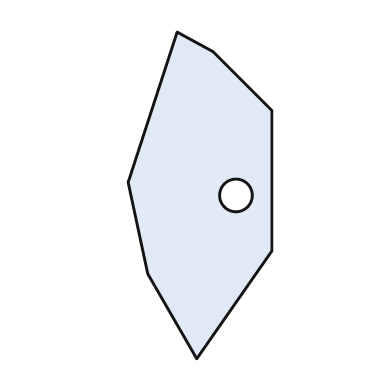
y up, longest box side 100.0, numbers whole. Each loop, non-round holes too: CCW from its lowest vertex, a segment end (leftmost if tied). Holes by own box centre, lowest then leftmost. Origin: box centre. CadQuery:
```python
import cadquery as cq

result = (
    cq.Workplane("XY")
    .moveTo(-1.0, -50.0)
    .lineTo(22.0, -17.0)
    .lineTo(22.0, 26.0)
    .lineTo(4.0, 44.0)
    .lineTo(-7.0, 50.0)
    .lineTo(-22.0, 4.0)
    .lineTo(-16.0, -24.0)
    .close()
    .moveTo(11.0, 0.0)
    .circle(5.0)
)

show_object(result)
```